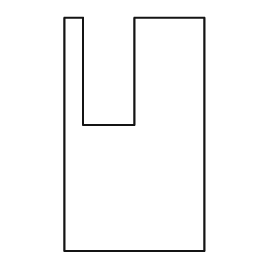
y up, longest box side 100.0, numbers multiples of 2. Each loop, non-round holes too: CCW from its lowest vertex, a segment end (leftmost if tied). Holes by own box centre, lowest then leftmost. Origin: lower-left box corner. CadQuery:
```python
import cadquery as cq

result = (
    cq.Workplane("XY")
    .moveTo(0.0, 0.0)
    .lineTo(60.0, 0.0)
    .lineTo(60.0, 100.0)
    .lineTo(30.0, 100.0)
    .lineTo(30.0, 54.0)
    .lineTo(8.0, 54.0)
    .lineTo(8.0, 100.0)
    .lineTo(0.0, 100.0)
    .close()
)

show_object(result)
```